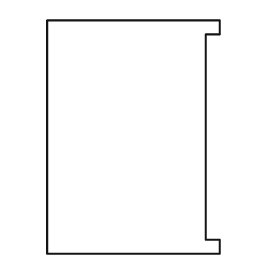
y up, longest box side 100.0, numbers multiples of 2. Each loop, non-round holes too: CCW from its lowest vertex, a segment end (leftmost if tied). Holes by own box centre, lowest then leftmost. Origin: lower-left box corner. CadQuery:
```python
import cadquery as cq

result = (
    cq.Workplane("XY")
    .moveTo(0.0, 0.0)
    .lineTo(74.0, 0.0)
    .lineTo(74.0, 6.0)
    .lineTo(68.0, 6.0)
    .lineTo(68.0, 94.0)
    .lineTo(74.0, 94.0)
    .lineTo(74.0, 100.0)
    .lineTo(0.0, 100.0)
    .close()
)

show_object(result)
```